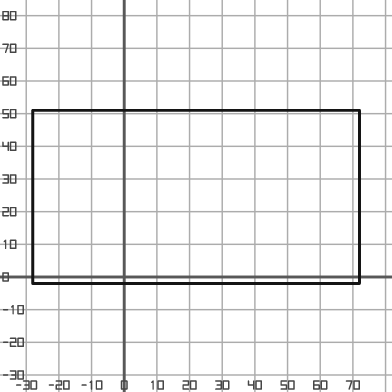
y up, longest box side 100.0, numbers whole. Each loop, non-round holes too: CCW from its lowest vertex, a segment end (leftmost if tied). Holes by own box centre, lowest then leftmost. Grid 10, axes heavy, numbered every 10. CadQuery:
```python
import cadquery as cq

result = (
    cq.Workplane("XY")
    .moveTo(-28.0, -2.0)
    .lineTo(72.0, -2.0)
    .lineTo(72.0, 51.0)
    .lineTo(-28.0, 51.0)
    .close()
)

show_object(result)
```